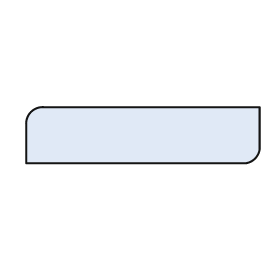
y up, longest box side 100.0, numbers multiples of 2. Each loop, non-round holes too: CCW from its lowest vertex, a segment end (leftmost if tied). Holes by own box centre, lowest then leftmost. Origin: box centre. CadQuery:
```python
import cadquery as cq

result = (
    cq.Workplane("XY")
    .moveTo(-50.0, -12.0)
    .lineTo(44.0, -12.0)
    .threePointArc((48.0, -10.0), (50.0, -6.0))
    .lineTo(50.0, 12.0)
    .lineTo(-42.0, 12.0)
    .threePointArc((-48.0, 10.0), (-50.0, 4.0))
    .close()
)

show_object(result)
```